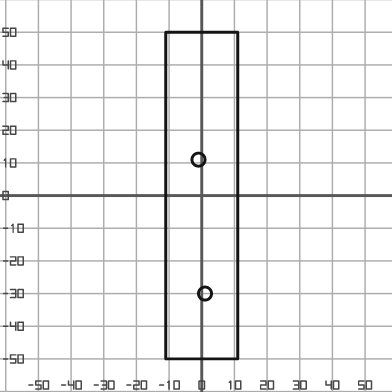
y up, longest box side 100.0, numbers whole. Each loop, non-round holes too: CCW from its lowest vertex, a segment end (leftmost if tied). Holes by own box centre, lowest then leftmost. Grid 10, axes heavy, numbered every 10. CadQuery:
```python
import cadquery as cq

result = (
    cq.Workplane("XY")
    .moveTo(-11.0, -50.0)
    .lineTo(11.0, -50.0)
    .lineTo(11.0, 50.0)
    .lineTo(-11.0, 50.0)
    .close()
    .moveTo(1.0, -30.0)
    .circle(2.0)
    .moveTo(-1.0, 11.0)
    .circle(2.0)
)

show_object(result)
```